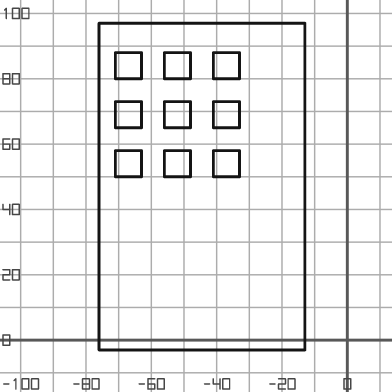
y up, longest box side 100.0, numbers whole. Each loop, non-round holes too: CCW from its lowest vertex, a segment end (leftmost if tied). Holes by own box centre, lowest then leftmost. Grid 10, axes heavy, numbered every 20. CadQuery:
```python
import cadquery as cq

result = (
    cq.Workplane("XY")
    .moveTo(-76.0, -3.0)
    .lineTo(-13.0, -3.0)
    .lineTo(-13.0, 97.0)
    .lineTo(-76.0, 97.0)
    .close()
    .moveTo(-71.0, 50.0)
    .lineTo(-63.0, 50.0)
    .lineTo(-63.0, 58.0)
    .lineTo(-71.0, 58.0)
    .close()
    .moveTo(-56.0, 50.0)
    .lineTo(-48.0, 50.0)
    .lineTo(-48.0, 58.0)
    .lineTo(-56.0, 58.0)
    .close()
    .moveTo(-41.0, 50.0)
    .lineTo(-33.0, 50.0)
    .lineTo(-33.0, 58.0)
    .lineTo(-41.0, 58.0)
    .close()
    .moveTo(-71.0, 65.0)
    .lineTo(-63.0, 65.0)
    .lineTo(-63.0, 73.0)
    .lineTo(-71.0, 73.0)
    .close()
    .moveTo(-56.0, 65.0)
    .lineTo(-48.0, 65.0)
    .lineTo(-48.0, 73.0)
    .lineTo(-56.0, 73.0)
    .close()
    .moveTo(-41.0, 65.0)
    .lineTo(-33.0, 65.0)
    .lineTo(-33.0, 73.0)
    .lineTo(-41.0, 73.0)
    .close()
    .moveTo(-71.0, 80.0)
    .lineTo(-63.0, 80.0)
    .lineTo(-63.0, 88.0)
    .lineTo(-71.0, 88.0)
    .close()
    .moveTo(-56.0, 80.0)
    .lineTo(-48.0, 80.0)
    .lineTo(-48.0, 88.0)
    .lineTo(-56.0, 88.0)
    .close()
    .moveTo(-41.0, 80.0)
    .lineTo(-33.0, 80.0)
    .lineTo(-33.0, 88.0)
    .lineTo(-41.0, 88.0)
    .close()
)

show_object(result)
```